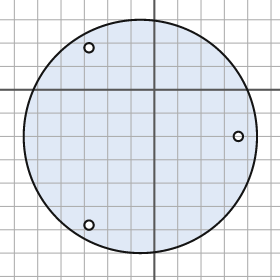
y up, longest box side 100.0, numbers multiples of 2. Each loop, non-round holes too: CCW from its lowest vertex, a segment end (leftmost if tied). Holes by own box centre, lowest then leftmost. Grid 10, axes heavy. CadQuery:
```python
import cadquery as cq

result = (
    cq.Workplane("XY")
    .moveTo(-6.0, -20.0)
    .circle(50.0)
    .moveTo(-28.0, -58.0)
    .circle(2.0)
    .moveTo(36.0, -20.0)
    .circle(2.0)
    .moveTo(-28.0, 18.0)
    .circle(2.0)
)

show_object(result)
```